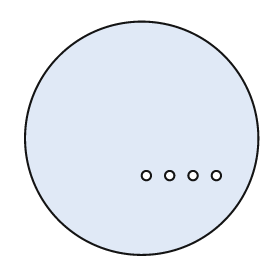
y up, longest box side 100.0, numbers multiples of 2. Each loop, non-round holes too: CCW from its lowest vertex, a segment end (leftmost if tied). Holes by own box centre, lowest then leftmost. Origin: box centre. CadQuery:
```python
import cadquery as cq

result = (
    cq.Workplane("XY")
    .moveTo(0.0, 0.0)
    .circle(50.0)
    .moveTo(2.0, -16.0)
    .circle(2.0)
    .moveTo(12.0, -16.0)
    .circle(2.0)
    .moveTo(22.0, -16.0)
    .circle(2.0)
    .moveTo(32.0, -16.0)
    .circle(2.0)
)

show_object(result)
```